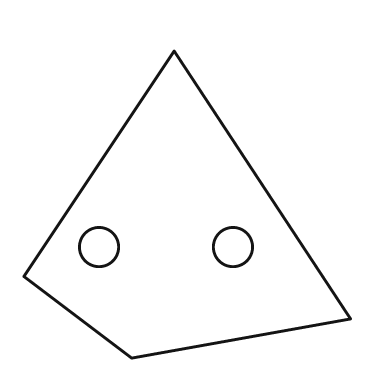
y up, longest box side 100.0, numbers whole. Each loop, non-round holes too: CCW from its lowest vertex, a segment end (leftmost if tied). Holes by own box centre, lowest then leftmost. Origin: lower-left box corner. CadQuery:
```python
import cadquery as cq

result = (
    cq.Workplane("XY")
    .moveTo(33.0, 0.0)
    .lineTo(100.0, 12.0)
    .lineTo(46.0, 94.0)
    .lineTo(0.0, 25.0)
    .close()
    .moveTo(23.0, 34.0)
    .circle(6.0)
    .moveTo(64.0, 34.0)
    .circle(6.0)
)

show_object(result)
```